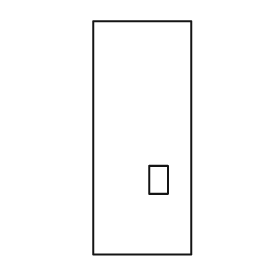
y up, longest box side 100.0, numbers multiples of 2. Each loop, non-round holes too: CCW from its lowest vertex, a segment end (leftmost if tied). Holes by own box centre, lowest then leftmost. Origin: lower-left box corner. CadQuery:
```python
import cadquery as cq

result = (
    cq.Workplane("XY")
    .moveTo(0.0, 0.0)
    .lineTo(42.0, 0.0)
    .lineTo(42.0, 100.0)
    .lineTo(0.0, 100.0)
    .close()
    .moveTo(24.0, 26.0)
    .lineTo(32.0, 26.0)
    .lineTo(32.0, 38.0)
    .lineTo(24.0, 38.0)
    .close()
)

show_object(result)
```